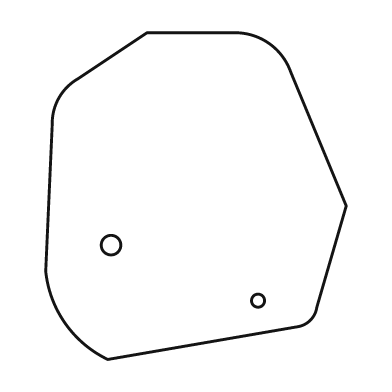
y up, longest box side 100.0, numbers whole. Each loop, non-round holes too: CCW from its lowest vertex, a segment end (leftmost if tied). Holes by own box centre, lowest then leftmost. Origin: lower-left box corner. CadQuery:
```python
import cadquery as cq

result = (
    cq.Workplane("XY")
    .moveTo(19.0, 0.0)
    .lineTo(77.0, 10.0)
    .threePointArc((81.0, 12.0), (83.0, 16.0))
    .lineTo(92.0, 47.0)
    .lineTo(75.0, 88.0)
    .threePointArc((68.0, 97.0), (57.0, 100.0))
    .lineTo(31.0, 100.0)
    .lineTo(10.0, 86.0)
    .threePointArc((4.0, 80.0), (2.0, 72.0))
    .lineTo(0.0, 27.0)
    .threePointArc((6.0, 11.0), (19.0, 0.0))
    .close()
    .moveTo(65.0, 18.0)
    .circle(2.0)
    .moveTo(20.0, 35.0)
    .circle(3.0)
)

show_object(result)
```